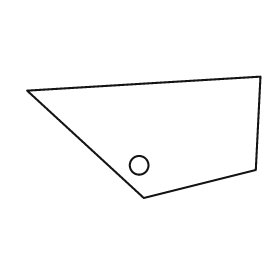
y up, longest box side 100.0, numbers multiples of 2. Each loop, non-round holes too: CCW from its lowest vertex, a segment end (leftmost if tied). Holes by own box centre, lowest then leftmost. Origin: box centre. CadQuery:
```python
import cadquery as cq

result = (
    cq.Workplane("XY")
    .moveTo(0.0, -26.0)
    .lineTo(48.0, -14.0)
    .lineTo(50.0, 26.0)
    .lineTo(-50.0, 20.0)
    .close()
    .moveTo(-2.0, -12.0)
    .circle(4.0)
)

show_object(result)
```